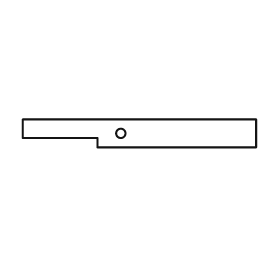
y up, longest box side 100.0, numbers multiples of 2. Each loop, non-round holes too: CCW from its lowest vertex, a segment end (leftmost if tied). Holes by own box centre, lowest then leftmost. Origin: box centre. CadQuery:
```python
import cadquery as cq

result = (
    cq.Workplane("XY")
    .moveTo(-18.0, -6.0)
    .lineTo(50.0, -6.0)
    .lineTo(50.0, 6.0)
    .lineTo(-50.0, 6.0)
    .lineTo(-50.0, -2.0)
    .lineTo(-18.0, -2.0)
    .close()
    .moveTo(-8.0, 0.0)
    .circle(2.0)
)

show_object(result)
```